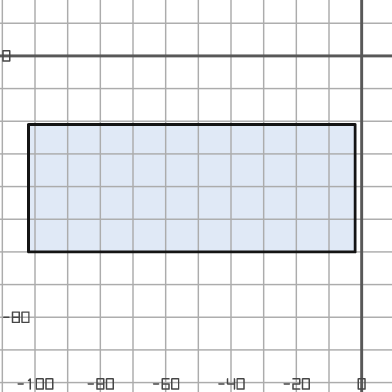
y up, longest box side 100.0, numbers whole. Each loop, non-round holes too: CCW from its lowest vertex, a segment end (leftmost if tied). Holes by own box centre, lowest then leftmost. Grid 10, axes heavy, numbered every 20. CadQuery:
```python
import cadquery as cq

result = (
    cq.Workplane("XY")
    .moveTo(-102.0, -60.0)
    .lineTo(-2.0, -60.0)
    .lineTo(-2.0, -21.0)
    .lineTo(-102.0, -21.0)
    .close()
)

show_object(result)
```